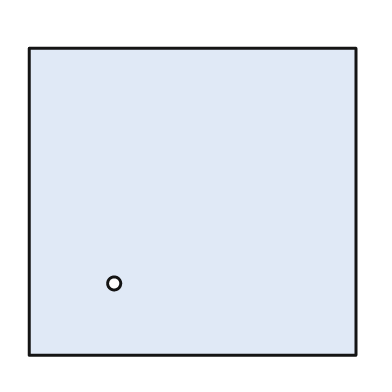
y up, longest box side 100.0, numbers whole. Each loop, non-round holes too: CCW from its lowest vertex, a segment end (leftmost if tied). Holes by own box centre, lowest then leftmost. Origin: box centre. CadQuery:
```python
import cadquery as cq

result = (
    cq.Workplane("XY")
    .moveTo(-50.0, -47.0)
    .lineTo(50.0, -47.0)
    .lineTo(50.0, 47.0)
    .lineTo(-50.0, 47.0)
    .close()
    .moveTo(-24.0, -25.0)
    .circle(2.0)
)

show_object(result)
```